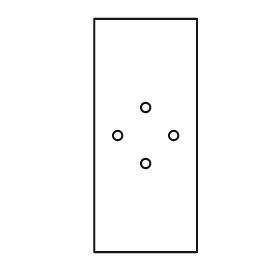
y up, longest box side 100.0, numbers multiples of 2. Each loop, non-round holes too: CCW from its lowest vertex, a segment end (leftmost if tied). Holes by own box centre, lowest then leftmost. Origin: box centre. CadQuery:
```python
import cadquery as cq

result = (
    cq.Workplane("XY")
    .moveTo(-22.0, -50.0)
    .lineTo(22.0, -50.0)
    .lineTo(22.0, 50.0)
    .lineTo(-22.0, 50.0)
    .close()
    .moveTo(0.0, -12.0)
    .circle(2.0)
    .moveTo(-12.0, 0.0)
    .circle(2.0)
    .moveTo(12.0, 0.0)
    .circle(2.0)
    .moveTo(0.0, 12.0)
    .circle(2.0)
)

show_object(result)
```